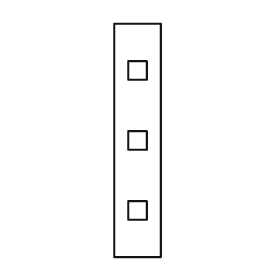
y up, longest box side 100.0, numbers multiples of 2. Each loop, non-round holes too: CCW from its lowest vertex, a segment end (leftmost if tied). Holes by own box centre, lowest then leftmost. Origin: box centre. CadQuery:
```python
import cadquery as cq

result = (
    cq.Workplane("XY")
    .moveTo(-10.0, -50.0)
    .lineTo(10.0, -50.0)
    .lineTo(10.0, 50.0)
    .lineTo(-10.0, 50.0)
    .close()
    .moveTo(-4.0, -34.0)
    .lineTo(4.0, -34.0)
    .lineTo(4.0, -26.0)
    .lineTo(-4.0, -26.0)
    .close()
    .moveTo(-4.0, -4.0)
    .lineTo(4.0, -4.0)
    .lineTo(4.0, 4.0)
    .lineTo(-4.0, 4.0)
    .close()
    .moveTo(-4.0, 26.0)
    .lineTo(4.0, 26.0)
    .lineTo(4.0, 34.0)
    .lineTo(-4.0, 34.0)
    .close()
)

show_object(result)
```